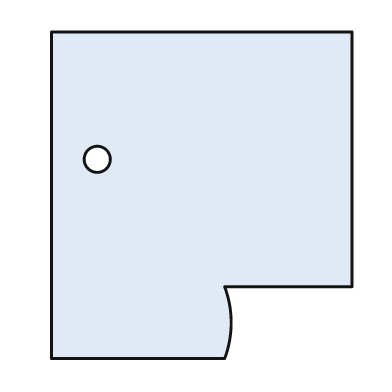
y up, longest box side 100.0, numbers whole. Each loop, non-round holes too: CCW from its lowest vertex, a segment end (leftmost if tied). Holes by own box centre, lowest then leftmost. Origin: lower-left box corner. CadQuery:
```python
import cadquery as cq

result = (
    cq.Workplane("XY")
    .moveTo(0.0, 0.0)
    .lineTo(53.0, 0.0)
    .threePointArc((55.0, 11.0), (53.0, 22.0))
    .lineTo(92.0, 22.0)
    .lineTo(92.0, 100.0)
    .lineTo(0.0, 100.0)
    .close()
    .moveTo(14.0, 61.0)
    .circle(4.0)
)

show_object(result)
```